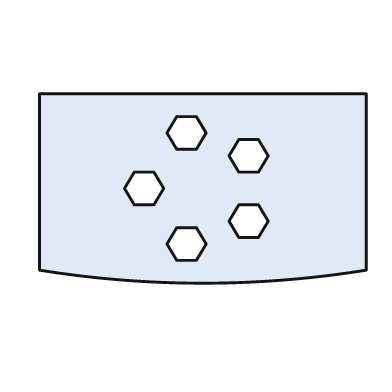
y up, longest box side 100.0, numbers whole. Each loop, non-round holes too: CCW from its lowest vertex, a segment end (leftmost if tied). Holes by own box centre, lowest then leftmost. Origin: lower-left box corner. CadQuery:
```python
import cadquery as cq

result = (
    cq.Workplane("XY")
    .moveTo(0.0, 4.0)
    .threePointArc((50.0, 0.0), (100.0, 4.0))
    .lineTo(100.0, 58.0)
    .lineTo(0.0, 58.0)
    .close()
    .moveTo(42.0, 7.0)
    .lineTo(48.0, 7.0)
    .lineTo(51.0, 12.0)
    .lineTo(48.0, 17.0)
    .lineTo(42.0, 17.0)
    .lineTo(39.0, 12.0)
    .close()
    .moveTo(61.0, 14.0)
    .lineTo(67.0, 14.0)
    .lineTo(70.0, 19.0)
    .lineTo(67.0, 24.0)
    .lineTo(61.0, 24.0)
    .lineTo(58.0, 19.0)
    .close()
    .moveTo(29.0, 24.0)
    .lineTo(35.0, 24.0)
    .lineTo(38.0, 29.0)
    .lineTo(35.0, 34.0)
    .lineTo(29.0, 34.0)
    .lineTo(26.0, 29.0)
    .close()
    .moveTo(61.0, 34.0)
    .lineTo(67.0, 34.0)
    .lineTo(70.0, 39.0)
    .lineTo(67.0, 44.0)
    .lineTo(61.0, 44.0)
    .lineTo(58.0, 39.0)
    .close()
    .moveTo(42.0, 41.0)
    .lineTo(48.0, 41.0)
    .lineTo(51.0, 46.0)
    .lineTo(48.0, 51.0)
    .lineTo(42.0, 51.0)
    .lineTo(39.0, 46.0)
    .close()
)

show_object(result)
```